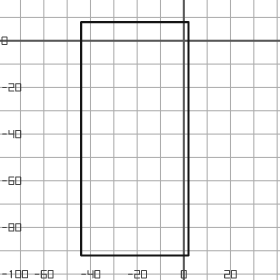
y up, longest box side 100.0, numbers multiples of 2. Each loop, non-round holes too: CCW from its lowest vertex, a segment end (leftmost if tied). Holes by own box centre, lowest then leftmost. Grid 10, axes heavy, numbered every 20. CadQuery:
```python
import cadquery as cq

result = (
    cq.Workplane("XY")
    .moveTo(-44.0, -92.0)
    .lineTo(2.0, -92.0)
    .lineTo(2.0, 8.0)
    .lineTo(-44.0, 8.0)
    .close()
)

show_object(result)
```